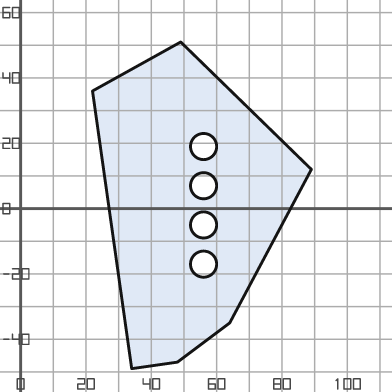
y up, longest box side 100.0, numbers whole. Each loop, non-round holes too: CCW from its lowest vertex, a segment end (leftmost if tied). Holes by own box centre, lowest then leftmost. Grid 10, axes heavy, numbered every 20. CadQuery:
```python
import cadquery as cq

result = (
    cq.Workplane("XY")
    .moveTo(34.0, -49.0)
    .lineTo(48.0, -47.0)
    .lineTo(64.0, -35.0)
    .lineTo(89.0, 12.0)
    .lineTo(49.0, 51.0)
    .lineTo(22.0, 36.0)
    .close()
    .moveTo(56.0, -17.0)
    .circle(4.0)
    .moveTo(56.0, -5.0)
    .circle(4.0)
    .moveTo(56.0, 7.0)
    .circle(4.0)
    .moveTo(56.0, 19.0)
    .circle(4.0)
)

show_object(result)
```